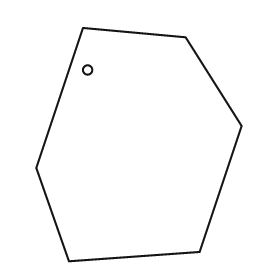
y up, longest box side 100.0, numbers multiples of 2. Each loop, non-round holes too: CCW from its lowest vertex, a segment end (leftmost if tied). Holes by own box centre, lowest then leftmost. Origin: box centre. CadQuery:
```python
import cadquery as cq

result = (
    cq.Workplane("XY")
    .moveTo(-30.0, -50.0)
    .lineTo(26.0, -46.0)
    .lineTo(44.0, 8.0)
    .lineTo(20.0, 46.0)
    .lineTo(-24.0, 50.0)
    .lineTo(-44.0, -10.0)
    .close()
    .moveTo(-22.0, 32.0)
    .circle(2.0)
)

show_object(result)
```